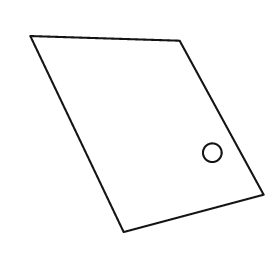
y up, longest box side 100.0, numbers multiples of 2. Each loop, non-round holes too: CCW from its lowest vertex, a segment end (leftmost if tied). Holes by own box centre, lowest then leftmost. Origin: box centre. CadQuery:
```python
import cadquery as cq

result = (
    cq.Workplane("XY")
    .moveTo(-10.0, -42.0)
    .lineTo(50.0, -26.0)
    .lineTo(14.0, 40.0)
    .lineTo(-50.0, 42.0)
    .close()
    .moveTo(28.0, -8.0)
    .circle(4.0)
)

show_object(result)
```